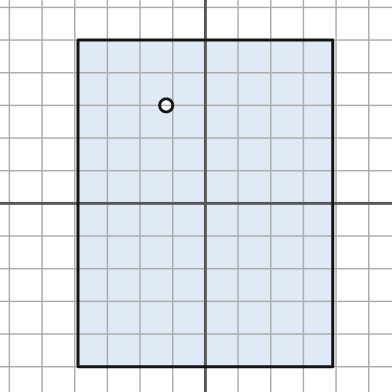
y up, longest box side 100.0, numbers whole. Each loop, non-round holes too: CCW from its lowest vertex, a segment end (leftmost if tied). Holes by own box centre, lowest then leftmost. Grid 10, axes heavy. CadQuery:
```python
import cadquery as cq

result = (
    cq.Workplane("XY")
    .moveTo(-39.0, -50.0)
    .lineTo(39.0, -50.0)
    .lineTo(39.0, 50.0)
    .lineTo(-39.0, 50.0)
    .close()
    .moveTo(-12.0, 30.0)
    .circle(2.0)
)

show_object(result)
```